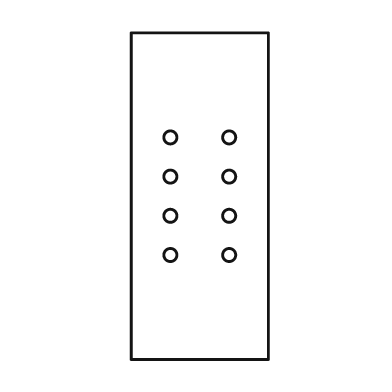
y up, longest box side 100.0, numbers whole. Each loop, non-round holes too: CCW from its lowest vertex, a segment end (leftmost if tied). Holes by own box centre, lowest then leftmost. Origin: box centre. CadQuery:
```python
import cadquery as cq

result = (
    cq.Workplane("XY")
    .moveTo(-21.0, -50.0)
    .lineTo(21.0, -50.0)
    .lineTo(21.0, 50.0)
    .lineTo(-21.0, 50.0)
    .close()
    .moveTo(-9.0, -18.0)
    .circle(2.0)
    .moveTo(9.0, -18.0)
    .circle(2.0)
    .moveTo(-9.0, -6.0)
    .circle(2.0)
    .moveTo(9.0, -6.0)
    .circle(2.0)
    .moveTo(-9.0, 6.0)
    .circle(2.0)
    .moveTo(9.0, 6.0)
    .circle(2.0)
    .moveTo(-9.0, 18.0)
    .circle(2.0)
    .moveTo(9.0, 18.0)
    .circle(2.0)
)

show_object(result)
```